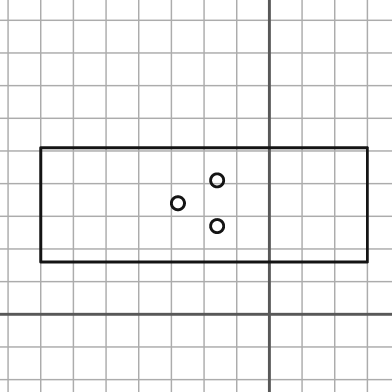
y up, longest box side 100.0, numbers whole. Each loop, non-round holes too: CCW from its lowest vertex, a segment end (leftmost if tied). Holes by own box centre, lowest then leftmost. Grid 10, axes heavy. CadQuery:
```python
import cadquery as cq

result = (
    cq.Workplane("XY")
    .moveTo(-70.0, 16.0)
    .lineTo(30.0, 16.0)
    .lineTo(30.0, 51.0)
    .lineTo(-70.0, 51.0)
    .close()
    .moveTo(-16.0, 27.0)
    .circle(2.0)
    .moveTo(-28.0, 34.0)
    .circle(2.0)
    .moveTo(-16.0, 41.0)
    .circle(2.0)
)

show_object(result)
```